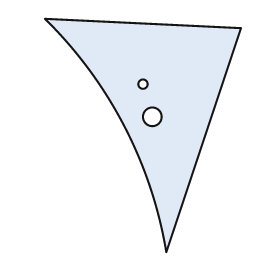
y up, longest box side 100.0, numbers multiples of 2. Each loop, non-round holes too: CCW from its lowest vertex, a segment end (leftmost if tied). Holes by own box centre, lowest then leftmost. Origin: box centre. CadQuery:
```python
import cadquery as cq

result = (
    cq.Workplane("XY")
    .moveTo(10.0, -50.0)
    .lineTo(42.0, 46.0)
    .lineTo(-42.0, 50.0)
    .threePointArc((-8.0, 4.0), (10.0, -50.0))
    .close()
    .moveTo(4.0, 8.0)
    .circle(4.0)
    .moveTo(0.0, 22.0)
    .circle(2.0)
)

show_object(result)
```